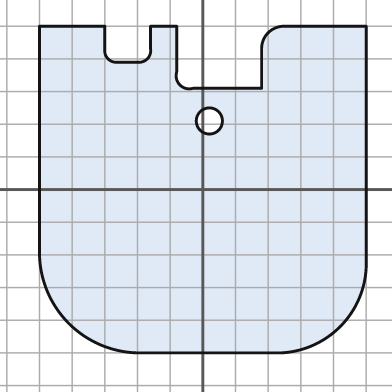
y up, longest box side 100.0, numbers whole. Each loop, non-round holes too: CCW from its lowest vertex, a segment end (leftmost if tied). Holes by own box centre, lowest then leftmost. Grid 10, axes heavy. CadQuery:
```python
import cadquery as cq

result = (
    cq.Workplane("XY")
    .moveTo(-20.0, -50.0)
    .lineTo(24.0, -50.0)
    .threePointArc((42.0, -42.0), (50.0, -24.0))
    .lineTo(50.0, 50.0)
    .lineTo(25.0, 50.0)
    .threePointArc((20.0, 48.0), (18.0, 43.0))
    .lineTo(18.0, 31.0)
    .lineTo(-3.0, 31.0)
    .threePointArc((-7.0, 32.0), (-8.0, 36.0))
    .lineTo(-8.0, 50.0)
    .lineTo(-16.0, 50.0)
    .lineTo(-16.0, 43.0)
    .threePointArc((-17.0, 40.0), (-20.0, 39.0))
    .lineTo(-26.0, 39.0)
    .threePointArc((-29.0, 40.0), (-30.0, 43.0))
    .lineTo(-30.0, 50.0)
    .lineTo(-50.0, 50.0)
    .lineTo(-50.0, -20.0)
    .threePointArc((-41.0, -41.0), (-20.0, -50.0))
    .close()
    .moveTo(2.0, 21.0)
    .circle(4.0)
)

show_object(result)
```